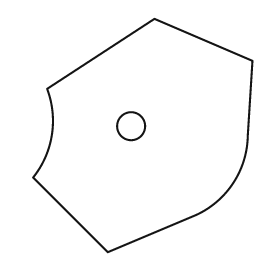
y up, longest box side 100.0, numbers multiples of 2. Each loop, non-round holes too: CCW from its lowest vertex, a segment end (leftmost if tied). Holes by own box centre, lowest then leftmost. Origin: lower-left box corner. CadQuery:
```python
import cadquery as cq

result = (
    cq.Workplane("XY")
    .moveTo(32.0, 0.0)
    .lineTo(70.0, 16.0)
    .threePointArc((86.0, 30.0), (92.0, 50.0))
    .lineTo(94.0, 82.0)
    .lineTo(52.0, 100.0)
    .lineTo(6.0, 70.0)
    .threePointArc((8.0, 50.0), (0.0, 32.0))
    .close()
    .moveTo(42.0, 54.0)
    .circle(6.0)
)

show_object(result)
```